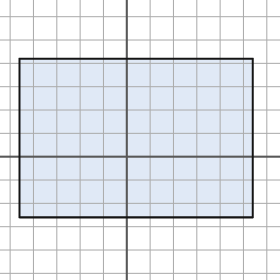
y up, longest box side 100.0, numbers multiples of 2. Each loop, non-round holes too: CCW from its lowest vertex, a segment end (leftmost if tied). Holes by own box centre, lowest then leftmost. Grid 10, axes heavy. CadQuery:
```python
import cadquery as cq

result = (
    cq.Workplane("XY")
    .moveTo(-46.0, -26.0)
    .lineTo(54.0, -26.0)
    .lineTo(54.0, 42.0)
    .lineTo(-46.0, 42.0)
    .close()
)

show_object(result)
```